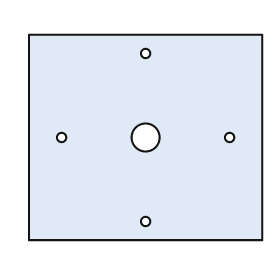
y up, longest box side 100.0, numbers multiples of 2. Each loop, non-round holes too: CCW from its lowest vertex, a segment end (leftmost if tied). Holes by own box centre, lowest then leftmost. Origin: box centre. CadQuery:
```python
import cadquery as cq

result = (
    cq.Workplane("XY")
    .moveTo(-50.0, -44.0)
    .lineTo(50.0, -44.0)
    .lineTo(50.0, 44.0)
    .lineTo(-50.0, 44.0)
    .close()
    .moveTo(0.0, -36.0)
    .circle(2.0)
    .moveTo(-36.0, 0.0)
    .circle(2.0)
    .moveTo(0.0, 0.0)
    .circle(6.0)
    .moveTo(36.0, 0.0)
    .circle(2.0)
    .moveTo(0.0, 36.0)
    .circle(2.0)
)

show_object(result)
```